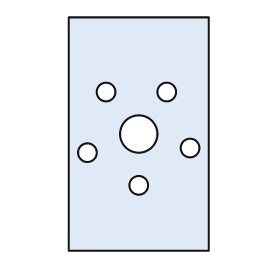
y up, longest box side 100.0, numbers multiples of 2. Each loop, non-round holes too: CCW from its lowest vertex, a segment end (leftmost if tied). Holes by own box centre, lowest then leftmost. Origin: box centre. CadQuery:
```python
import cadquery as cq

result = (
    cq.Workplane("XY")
    .moveTo(-30.0, -50.0)
    .lineTo(30.0, -50.0)
    .lineTo(30.0, 50.0)
    .lineTo(-30.0, 50.0)
    .close()
    .moveTo(0.0, -22.0)
    .circle(4.0)
    .moveTo(-22.0, -8.0)
    .circle(4.0)
    .moveTo(22.0, -6.0)
    .circle(4.0)
    .moveTo(0.0, 0.0)
    .circle(8.0)
    .moveTo(-14.0, 18.0)
    .circle(4.0)
    .moveTo(12.0, 18.0)
    .circle(4.0)
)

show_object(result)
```